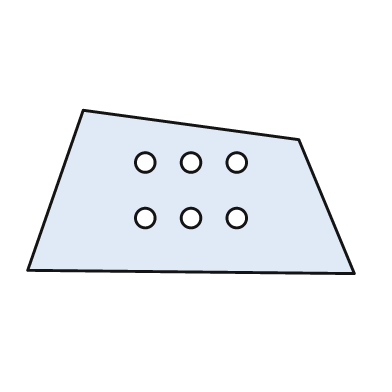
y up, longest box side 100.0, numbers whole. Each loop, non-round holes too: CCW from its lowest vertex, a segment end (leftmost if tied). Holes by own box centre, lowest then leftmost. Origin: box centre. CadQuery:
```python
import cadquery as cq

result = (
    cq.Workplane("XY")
    .moveTo(50.0, -25.0)
    .lineTo(33.0, 16.0)
    .lineTo(-33.0, 25.0)
    .lineTo(-50.0, -24.0)
    .close()
    .moveTo(-14.0, -8.0)
    .circle(3.0)
    .moveTo(0.0, -8.0)
    .circle(3.0)
    .moveTo(14.0, -8.0)
    .circle(3.0)
    .moveTo(-14.0, 9.0)
    .circle(3.0)
    .moveTo(0.0, 9.0)
    .circle(3.0)
    .moveTo(14.0, 9.0)
    .circle(3.0)
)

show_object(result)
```